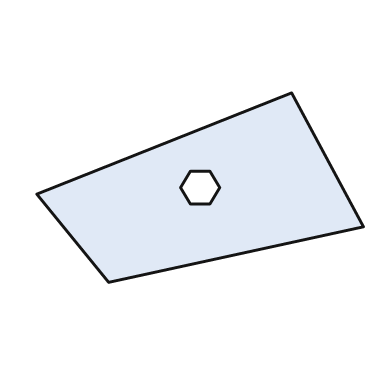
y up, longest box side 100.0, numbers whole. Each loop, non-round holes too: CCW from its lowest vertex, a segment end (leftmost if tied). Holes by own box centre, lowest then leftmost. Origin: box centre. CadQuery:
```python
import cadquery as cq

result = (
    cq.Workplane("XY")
    .moveTo(-28.0, -29.0)
    .lineTo(50.0, -12.0)
    .lineTo(28.0, 29.0)
    .lineTo(-50.0, -2.0)
    .close()
    .moveTo(-3.0, -5.0)
    .lineTo(3.0, -5.0)
    .lineTo(6.0, 0.0)
    .lineTo(3.0, 5.0)
    .lineTo(-3.0, 5.0)
    .lineTo(-6.0, 0.0)
    .close()
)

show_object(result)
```